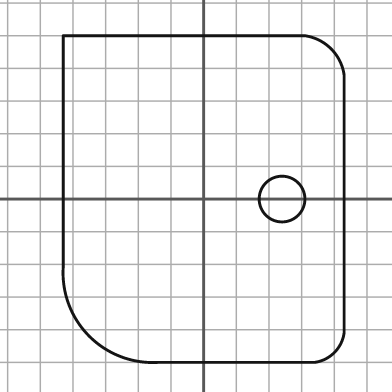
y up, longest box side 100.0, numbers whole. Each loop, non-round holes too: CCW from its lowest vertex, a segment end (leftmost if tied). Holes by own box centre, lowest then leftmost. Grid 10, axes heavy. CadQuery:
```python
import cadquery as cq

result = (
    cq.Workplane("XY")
    .moveTo(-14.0, -50.0)
    .lineTo(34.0, -50.0)
    .threePointArc((40.0, -47.0), (43.0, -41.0))
    .lineTo(43.0, 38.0)
    .threePointArc((39.0, 46.0), (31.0, 50.0))
    .lineTo(-43.0, 50.0)
    .lineTo(-43.0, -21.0)
    .threePointArc((-35.0, -42.0), (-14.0, -50.0))
    .close()
    .moveTo(24.0, 0.0)
    .circle(7.0)
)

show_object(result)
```